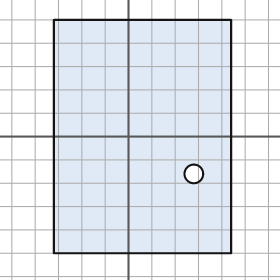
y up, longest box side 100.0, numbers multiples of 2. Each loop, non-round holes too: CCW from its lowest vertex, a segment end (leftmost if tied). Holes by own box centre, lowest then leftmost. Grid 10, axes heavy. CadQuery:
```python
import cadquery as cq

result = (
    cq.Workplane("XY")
    .moveTo(-32.0, -50.0)
    .lineTo(44.0, -50.0)
    .lineTo(44.0, 50.0)
    .lineTo(-32.0, 50.0)
    .close()
    .moveTo(28.0, -16.0)
    .circle(4.0)
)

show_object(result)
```